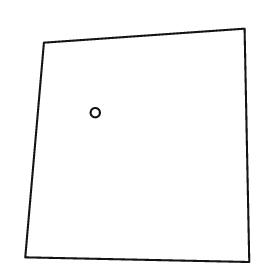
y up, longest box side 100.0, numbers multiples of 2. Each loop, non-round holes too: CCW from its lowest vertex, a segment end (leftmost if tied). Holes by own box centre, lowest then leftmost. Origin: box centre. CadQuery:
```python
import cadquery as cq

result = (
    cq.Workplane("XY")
    .moveTo(48.0, -50.0)
    .lineTo(46.0, 50.0)
    .lineTo(-40.0, 44.0)
    .lineTo(-48.0, -48.0)
    .close()
    .moveTo(-18.0, 14.0)
    .circle(2.0)
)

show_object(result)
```